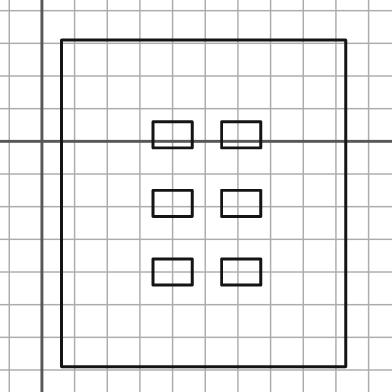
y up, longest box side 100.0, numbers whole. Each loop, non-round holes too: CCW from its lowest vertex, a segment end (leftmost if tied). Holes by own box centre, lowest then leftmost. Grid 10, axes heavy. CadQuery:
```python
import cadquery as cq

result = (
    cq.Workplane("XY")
    .moveTo(6.0, -69.0)
    .lineTo(93.0, -69.0)
    .lineTo(93.0, 31.0)
    .lineTo(6.0, 31.0)
    .close()
    .moveTo(34.0, -44.0)
    .lineTo(46.0, -44.0)
    .lineTo(46.0, -36.0)
    .lineTo(34.0, -36.0)
    .close()
    .moveTo(55.0, -44.0)
    .lineTo(67.0, -44.0)
    .lineTo(67.0, -36.0)
    .lineTo(55.0, -36.0)
    .close()
    .moveTo(34.0, -23.0)
    .lineTo(46.0, -23.0)
    .lineTo(46.0, -15.0)
    .lineTo(34.0, -15.0)
    .close()
    .moveTo(55.0, -23.0)
    .lineTo(67.0, -23.0)
    .lineTo(67.0, -15.0)
    .lineTo(55.0, -15.0)
    .close()
    .moveTo(34.0, -2.0)
    .lineTo(46.0, -2.0)
    .lineTo(46.0, 6.0)
    .lineTo(34.0, 6.0)
    .close()
    .moveTo(55.0, -2.0)
    .lineTo(67.0, -2.0)
    .lineTo(67.0, 6.0)
    .lineTo(55.0, 6.0)
    .close()
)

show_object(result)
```